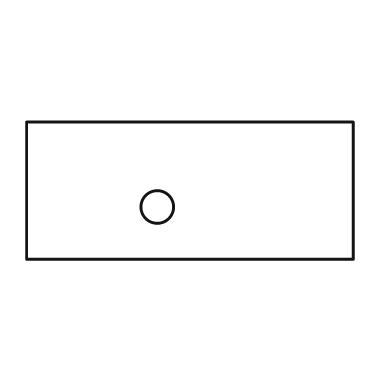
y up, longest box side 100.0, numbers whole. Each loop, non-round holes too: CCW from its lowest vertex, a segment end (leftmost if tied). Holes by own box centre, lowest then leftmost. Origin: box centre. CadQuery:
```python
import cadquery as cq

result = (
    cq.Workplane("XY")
    .moveTo(-50.0, -21.0)
    .lineTo(50.0, -21.0)
    .lineTo(50.0, 21.0)
    .lineTo(-50.0, 21.0)
    .close()
    .moveTo(-10.0, -5.0)
    .circle(5.0)
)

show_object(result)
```